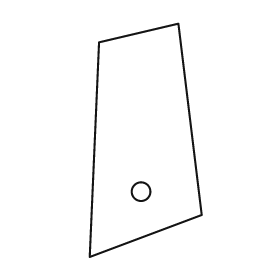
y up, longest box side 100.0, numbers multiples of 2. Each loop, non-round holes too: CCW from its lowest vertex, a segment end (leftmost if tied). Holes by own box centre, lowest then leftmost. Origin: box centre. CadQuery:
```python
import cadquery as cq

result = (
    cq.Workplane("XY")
    .moveTo(-24.0, -50.0)
    .lineTo(24.0, -32.0)
    .lineTo(14.0, 50.0)
    .lineTo(-20.0, 42.0)
    .close()
    .moveTo(-2.0, -22.0)
    .circle(4.0)
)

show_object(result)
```